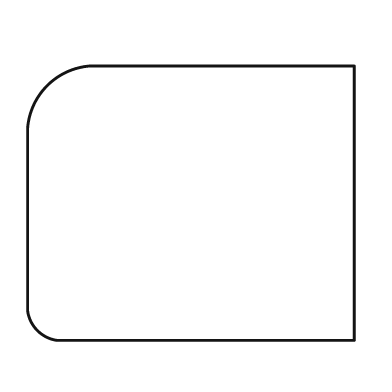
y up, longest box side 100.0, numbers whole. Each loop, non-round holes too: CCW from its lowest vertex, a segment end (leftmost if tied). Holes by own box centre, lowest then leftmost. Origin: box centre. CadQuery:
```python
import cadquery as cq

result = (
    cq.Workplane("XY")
    .moveTo(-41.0, -42.0)
    .lineTo(50.0, -42.0)
    .lineTo(50.0, 42.0)
    .lineTo(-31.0, 42.0)
    .threePointArc((-44.0, 36.0), (-50.0, 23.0))
    .lineTo(-50.0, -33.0)
    .threePointArc((-47.0, -39.0), (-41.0, -42.0))
    .close()
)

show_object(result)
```